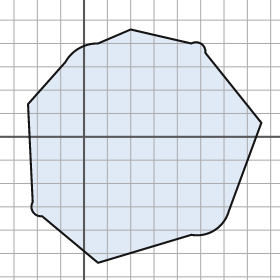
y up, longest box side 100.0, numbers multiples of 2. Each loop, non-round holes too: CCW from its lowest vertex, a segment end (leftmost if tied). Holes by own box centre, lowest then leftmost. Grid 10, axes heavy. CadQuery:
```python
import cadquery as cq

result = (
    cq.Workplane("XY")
    .moveTo(6.0, -54.0)
    .lineTo(46.0, -42.0)
    .threePointArc((56.0, -40.0), (62.0, -32.0))
    .lineTo(76.0, 6.0)
    .lineTo(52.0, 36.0)
    .threePointArc((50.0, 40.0), (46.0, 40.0))
    .lineTo(20.0, 46.0)
    .lineTo(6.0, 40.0)
    .threePointArc((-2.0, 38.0), (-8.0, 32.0))
    .lineTo(-24.0, 14.0)
    .lineTo(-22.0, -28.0)
    .threePointArc((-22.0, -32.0), (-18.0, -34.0))
    .close()
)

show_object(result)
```